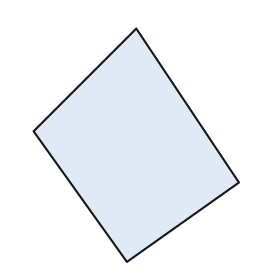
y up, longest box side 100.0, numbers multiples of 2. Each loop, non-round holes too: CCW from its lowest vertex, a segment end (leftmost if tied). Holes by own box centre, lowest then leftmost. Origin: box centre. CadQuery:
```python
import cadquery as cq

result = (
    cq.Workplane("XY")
    .moveTo(-4.0, -50.0)
    .lineTo(44.0, -16.0)
    .lineTo(0.0, 50.0)
    .lineTo(-44.0, 6.0)
    .close()
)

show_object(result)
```